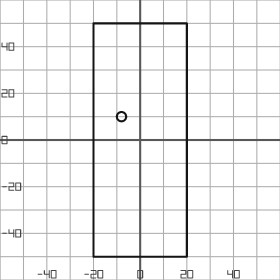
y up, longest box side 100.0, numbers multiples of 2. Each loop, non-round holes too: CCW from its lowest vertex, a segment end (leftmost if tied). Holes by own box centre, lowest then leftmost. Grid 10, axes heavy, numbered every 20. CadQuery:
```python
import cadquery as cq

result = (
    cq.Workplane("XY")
    .moveTo(-20.0, -50.0)
    .lineTo(20.0, -50.0)
    .lineTo(20.0, 50.0)
    .lineTo(-20.0, 50.0)
    .close()
    .moveTo(-8.0, 10.0)
    .circle(2.0)
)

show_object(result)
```